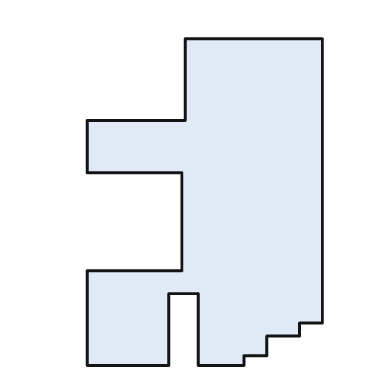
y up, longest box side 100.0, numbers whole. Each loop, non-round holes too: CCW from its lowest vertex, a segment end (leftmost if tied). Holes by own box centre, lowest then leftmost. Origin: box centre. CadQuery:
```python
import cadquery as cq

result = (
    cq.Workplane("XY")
    .moveTo(-36.0, -50.0)
    .lineTo(-11.0, -50.0)
    .lineTo(-11.0, -28.0)
    .lineTo(-2.0, -28.0)
    .lineTo(-2.0, -50.0)
    .lineTo(12.0, -50.0)
    .lineTo(12.0, -47.0)
    .lineTo(19.0, -47.0)
    .lineTo(19.0, -41.0)
    .lineTo(29.0, -41.0)
    .lineTo(29.0, -37.0)
    .lineTo(36.0, -37.0)
    .lineTo(36.0, 50.0)
    .lineTo(-6.0, 50.0)
    .lineTo(-6.0, 25.0)
    .lineTo(-36.0, 25.0)
    .lineTo(-36.0, 9.0)
    .lineTo(-7.0, 9.0)
    .lineTo(-7.0, -21.0)
    .lineTo(-36.0, -21.0)
    .close()
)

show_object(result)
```